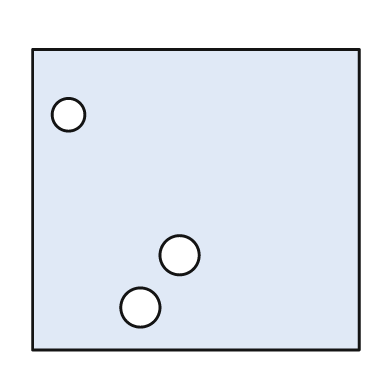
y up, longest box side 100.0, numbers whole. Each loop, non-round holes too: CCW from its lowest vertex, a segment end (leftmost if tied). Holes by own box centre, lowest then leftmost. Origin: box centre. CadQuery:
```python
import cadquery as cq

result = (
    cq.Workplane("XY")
    .moveTo(-50.0, -46.0)
    .lineTo(50.0, -46.0)
    .lineTo(50.0, 46.0)
    .lineTo(-50.0, 46.0)
    .close()
    .moveTo(-17.0, -33.0)
    .circle(6.0)
    .moveTo(-5.0, -17.0)
    .circle(6.0)
    .moveTo(-39.0, 26.0)
    .circle(5.0)
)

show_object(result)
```